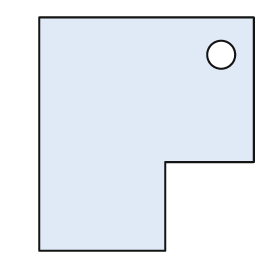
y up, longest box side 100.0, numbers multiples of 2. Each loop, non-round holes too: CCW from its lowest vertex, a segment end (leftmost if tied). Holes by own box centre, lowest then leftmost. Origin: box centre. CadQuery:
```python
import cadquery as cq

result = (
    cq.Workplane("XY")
    .moveTo(-46.0, -50.0)
    .lineTo(8.0, -50.0)
    .lineTo(8.0, -12.0)
    .lineTo(46.0, -12.0)
    .lineTo(46.0, 50.0)
    .lineTo(-46.0, 50.0)
    .close()
    .moveTo(32.0, 34.0)
    .circle(6.0)
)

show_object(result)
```